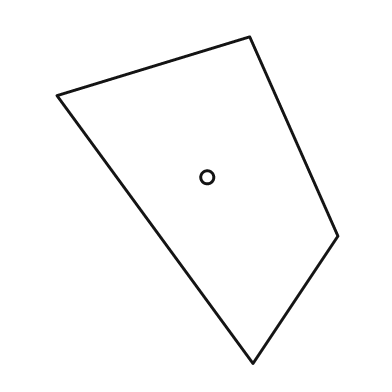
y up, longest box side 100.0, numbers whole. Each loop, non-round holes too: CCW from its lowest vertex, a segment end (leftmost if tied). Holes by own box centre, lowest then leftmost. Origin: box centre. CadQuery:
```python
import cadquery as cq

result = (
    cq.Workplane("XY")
    .moveTo(17.0, -50.0)
    .lineTo(43.0, -11.0)
    .lineTo(16.0, 50.0)
    .lineTo(-43.0, 32.0)
    .close()
    .moveTo(3.0, 7.0)
    .circle(2.0)
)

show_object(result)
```